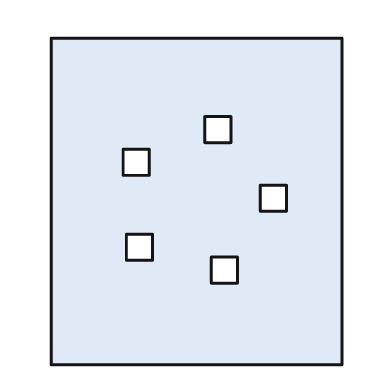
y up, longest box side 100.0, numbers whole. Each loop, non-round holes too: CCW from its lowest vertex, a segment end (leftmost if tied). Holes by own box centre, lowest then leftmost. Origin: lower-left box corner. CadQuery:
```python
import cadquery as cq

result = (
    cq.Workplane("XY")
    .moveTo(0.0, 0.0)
    .lineTo(89.0, 0.0)
    .lineTo(89.0, 100.0)
    .lineTo(0.0, 100.0)
    .close()
    .moveTo(49.0, 25.0)
    .lineTo(57.0, 25.0)
    .lineTo(57.0, 33.0)
    .lineTo(49.0, 33.0)
    .close()
    .moveTo(23.0, 32.0)
    .lineTo(31.0, 32.0)
    .lineTo(31.0, 40.0)
    .lineTo(23.0, 40.0)
    .close()
    .moveTo(64.0, 47.0)
    .lineTo(72.0, 47.0)
    .lineTo(72.0, 55.0)
    .lineTo(64.0, 55.0)
    .close()
    .moveTo(22.0, 58.0)
    .lineTo(30.0, 58.0)
    .lineTo(30.0, 66.0)
    .lineTo(22.0, 66.0)
    .close()
    .moveTo(47.0, 68.0)
    .lineTo(55.0, 68.0)
    .lineTo(55.0, 76.0)
    .lineTo(47.0, 76.0)
    .close()
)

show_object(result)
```